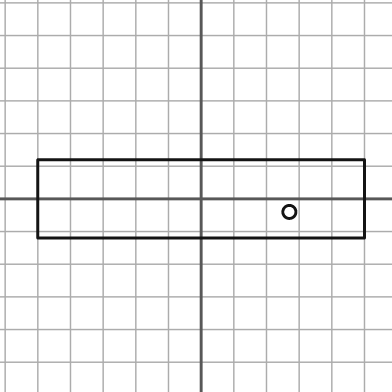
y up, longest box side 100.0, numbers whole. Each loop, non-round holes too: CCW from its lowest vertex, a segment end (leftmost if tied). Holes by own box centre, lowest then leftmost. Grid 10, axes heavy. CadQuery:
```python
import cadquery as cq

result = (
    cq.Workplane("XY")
    .moveTo(-50.0, -12.0)
    .lineTo(50.0, -12.0)
    .lineTo(50.0, 12.0)
    .lineTo(-50.0, 12.0)
    .close()
    .moveTo(27.0, -4.0)
    .circle(2.0)
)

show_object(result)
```